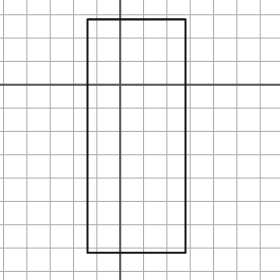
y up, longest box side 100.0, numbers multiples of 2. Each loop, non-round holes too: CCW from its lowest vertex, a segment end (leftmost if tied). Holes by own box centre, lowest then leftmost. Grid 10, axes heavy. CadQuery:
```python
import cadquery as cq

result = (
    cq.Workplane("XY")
    .moveTo(-14.0, -72.0)
    .lineTo(28.0, -72.0)
    .lineTo(28.0, 28.0)
    .lineTo(-14.0, 28.0)
    .close()
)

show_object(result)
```